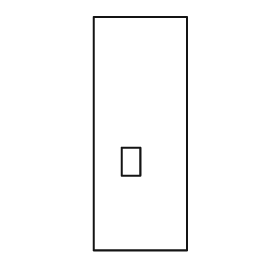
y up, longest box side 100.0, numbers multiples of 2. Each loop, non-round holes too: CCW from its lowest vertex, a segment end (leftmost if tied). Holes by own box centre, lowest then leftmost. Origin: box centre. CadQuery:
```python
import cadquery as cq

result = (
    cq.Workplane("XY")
    .moveTo(-20.0, -50.0)
    .lineTo(20.0, -50.0)
    .lineTo(20.0, 50.0)
    .lineTo(-20.0, 50.0)
    .close()
    .moveTo(-8.0, -18.0)
    .lineTo(0.0, -18.0)
    .lineTo(0.0, -6.0)
    .lineTo(-8.0, -6.0)
    .close()
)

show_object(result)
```